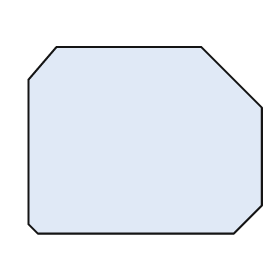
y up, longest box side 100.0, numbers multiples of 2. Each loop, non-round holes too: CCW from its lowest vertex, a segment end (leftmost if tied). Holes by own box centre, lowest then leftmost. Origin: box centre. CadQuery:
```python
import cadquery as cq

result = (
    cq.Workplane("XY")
    .moveTo(-46.0, -40.0)
    .lineTo(38.0, -40.0)
    .lineTo(50.0, -28.0)
    .lineTo(50.0, 14.0)
    .lineTo(24.0, 40.0)
    .lineTo(-38.0, 40.0)
    .lineTo(-50.0, 26.0)
    .lineTo(-50.0, -36.0)
    .close()
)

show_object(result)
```